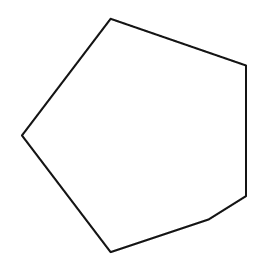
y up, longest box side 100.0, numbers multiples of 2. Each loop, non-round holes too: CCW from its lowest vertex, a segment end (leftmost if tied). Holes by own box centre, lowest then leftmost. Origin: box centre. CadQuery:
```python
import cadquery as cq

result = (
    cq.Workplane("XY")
    .moveTo(-10.0, -50.0)
    .lineTo(32.0, -36.0)
    .lineTo(48.0, -26.0)
    .lineTo(48.0, 30.0)
    .lineTo(-10.0, 50.0)
    .lineTo(-48.0, 0.0)
    .close()
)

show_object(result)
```